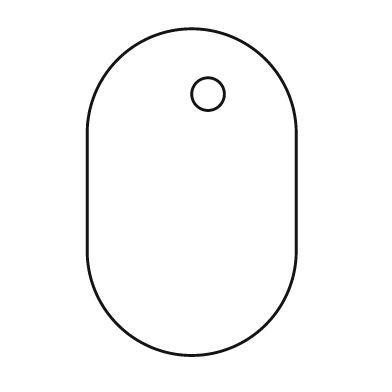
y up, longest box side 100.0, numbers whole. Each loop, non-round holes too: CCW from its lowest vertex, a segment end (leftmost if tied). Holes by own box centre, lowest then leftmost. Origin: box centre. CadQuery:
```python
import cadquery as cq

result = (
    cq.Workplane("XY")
    .moveTo(-32.0, -18.0)
    .threePointArc((0.0, -50.0), (32.0, -18.0))
    .lineTo(32.0, 18.0)
    .threePointArc((0.0, 50.0), (-32.0, 18.0))
    .close()
    .moveTo(5.0, 30.0)
    .circle(5.0)
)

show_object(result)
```